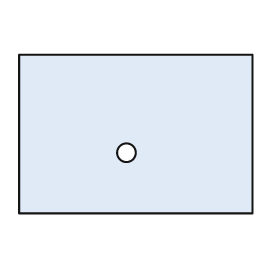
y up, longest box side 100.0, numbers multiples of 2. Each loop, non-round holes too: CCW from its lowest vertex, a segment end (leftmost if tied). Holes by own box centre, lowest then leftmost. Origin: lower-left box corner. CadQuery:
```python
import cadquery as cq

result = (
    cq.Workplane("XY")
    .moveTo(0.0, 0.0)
    .lineTo(100.0, 0.0)
    .lineTo(100.0, 68.0)
    .lineTo(0.0, 68.0)
    .close()
    .moveTo(46.0, 26.0)
    .circle(4.0)
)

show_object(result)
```